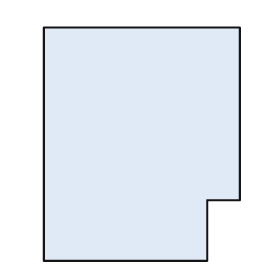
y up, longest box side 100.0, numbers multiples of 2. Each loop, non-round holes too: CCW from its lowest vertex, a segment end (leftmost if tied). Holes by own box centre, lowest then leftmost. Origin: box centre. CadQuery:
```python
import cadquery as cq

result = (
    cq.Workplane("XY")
    .moveTo(-42.0, -50.0)
    .lineTo(28.0, -50.0)
    .lineTo(28.0, -24.0)
    .lineTo(42.0, -24.0)
    .lineTo(42.0, 50.0)
    .lineTo(-42.0, 50.0)
    .close()
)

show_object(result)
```